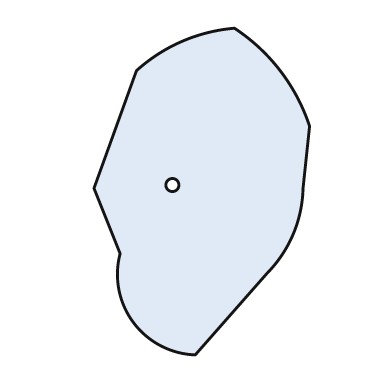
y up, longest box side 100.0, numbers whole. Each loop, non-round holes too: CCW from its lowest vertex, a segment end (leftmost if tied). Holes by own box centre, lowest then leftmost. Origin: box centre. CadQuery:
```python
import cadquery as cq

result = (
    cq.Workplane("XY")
    .moveTo(-2.0, -50.0)
    .lineTo(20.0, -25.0)
    .threePointArc((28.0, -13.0), (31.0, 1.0))
    .lineTo(33.0, 20.0)
    .threePointArc((24.0, 37.0), (10.0, 50.0))
    .threePointArc((-6.0, 46.0), (-20.0, 37.0))
    .lineTo(-33.0, 1.0)
    .lineTo(-25.0, -19.0)
    .threePointArc((-21.0, -40.0), (-2.0, -50.0))
    .close()
    .moveTo(-9.0, 2.0)
    .circle(2.0)
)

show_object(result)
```